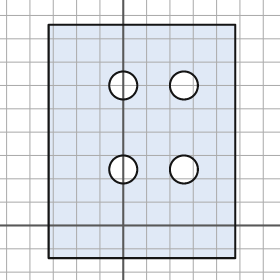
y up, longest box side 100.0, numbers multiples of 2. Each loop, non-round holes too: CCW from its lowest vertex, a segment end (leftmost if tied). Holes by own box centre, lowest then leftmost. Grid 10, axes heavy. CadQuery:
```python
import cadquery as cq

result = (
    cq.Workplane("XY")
    .moveTo(-32.0, -14.0)
    .lineTo(48.0, -14.0)
    .lineTo(48.0, 86.0)
    .lineTo(-32.0, 86.0)
    .close()
    .moveTo(0.0, 24.0)
    .circle(6.0)
    .moveTo(26.0, 24.0)
    .circle(6.0)
    .moveTo(0.0, 60.0)
    .circle(6.0)
    .moveTo(26.0, 60.0)
    .circle(6.0)
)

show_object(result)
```